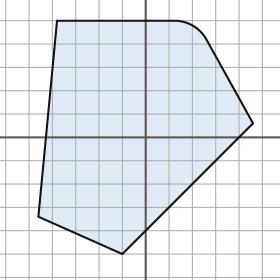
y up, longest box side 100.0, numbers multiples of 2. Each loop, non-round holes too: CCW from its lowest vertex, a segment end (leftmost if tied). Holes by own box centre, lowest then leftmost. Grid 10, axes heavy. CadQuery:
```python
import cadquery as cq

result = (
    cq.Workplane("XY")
    .moveTo(-10.0, -50.0)
    .lineTo(46.0, 6.0)
    .lineTo(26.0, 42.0)
    .threePointArc((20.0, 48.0), (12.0, 50.0))
    .lineTo(-38.0, 50.0)
    .lineTo(-46.0, -34.0)
    .close()
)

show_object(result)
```